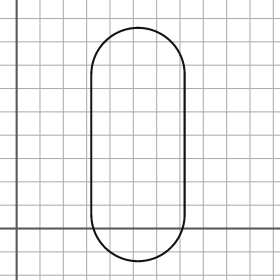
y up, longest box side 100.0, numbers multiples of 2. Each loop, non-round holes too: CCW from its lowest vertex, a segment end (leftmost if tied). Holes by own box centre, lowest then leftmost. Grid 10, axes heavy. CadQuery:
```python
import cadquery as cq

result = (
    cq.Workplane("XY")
    .moveTo(32.0, 6.0)
    .threePointArc((52.0, -14.0), (72.0, 6.0))
    .lineTo(72.0, 66.0)
    .threePointArc((52.0, 86.0), (32.0, 66.0))
    .close()
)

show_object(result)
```